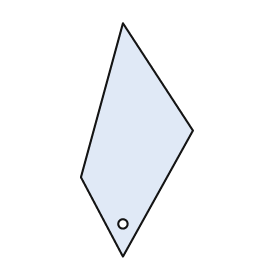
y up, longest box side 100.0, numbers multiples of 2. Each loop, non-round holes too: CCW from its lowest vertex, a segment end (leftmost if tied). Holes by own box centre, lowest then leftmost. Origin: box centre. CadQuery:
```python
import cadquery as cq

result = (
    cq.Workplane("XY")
    .moveTo(-6.0, -50.0)
    .lineTo(24.0, 4.0)
    .lineTo(-6.0, 50.0)
    .lineTo(-24.0, -16.0)
    .close()
    .moveTo(-6.0, -36.0)
    .circle(2.0)
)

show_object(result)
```